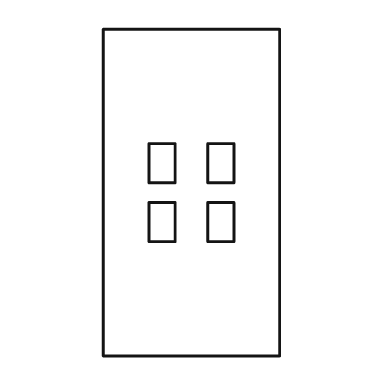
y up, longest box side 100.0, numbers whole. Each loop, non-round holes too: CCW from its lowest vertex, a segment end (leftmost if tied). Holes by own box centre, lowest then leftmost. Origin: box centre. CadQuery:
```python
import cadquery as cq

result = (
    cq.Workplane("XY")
    .moveTo(-27.0, -50.0)
    .lineTo(27.0, -50.0)
    .lineTo(27.0, 50.0)
    .lineTo(-27.0, 50.0)
    .close()
    .moveTo(-13.0, -15.0)
    .lineTo(-5.0, -15.0)
    .lineTo(-5.0, -3.0)
    .lineTo(-13.0, -3.0)
    .close()
    .moveTo(5.0, -15.0)
    .lineTo(13.0, -15.0)
    .lineTo(13.0, -3.0)
    .lineTo(5.0, -3.0)
    .close()
    .moveTo(-13.0, 3.0)
    .lineTo(-5.0, 3.0)
    .lineTo(-5.0, 15.0)
    .lineTo(-13.0, 15.0)
    .close()
    .moveTo(5.0, 3.0)
    .lineTo(13.0, 3.0)
    .lineTo(13.0, 15.0)
    .lineTo(5.0, 15.0)
    .close()
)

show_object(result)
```